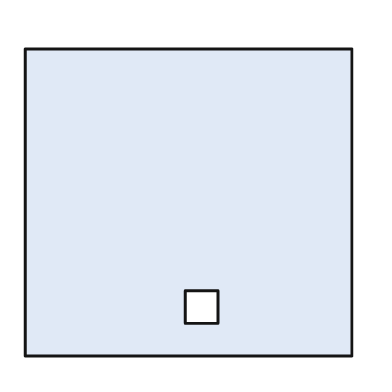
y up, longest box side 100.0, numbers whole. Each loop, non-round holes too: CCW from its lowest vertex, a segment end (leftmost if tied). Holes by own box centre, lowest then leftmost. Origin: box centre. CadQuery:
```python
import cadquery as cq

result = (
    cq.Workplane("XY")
    .moveTo(-50.0, -47.0)
    .lineTo(50.0, -47.0)
    .lineTo(50.0, 47.0)
    .lineTo(-50.0, 47.0)
    .close()
    .moveTo(-1.0, -37.0)
    .lineTo(9.0, -37.0)
    .lineTo(9.0, -27.0)
    .lineTo(-1.0, -27.0)
    .close()
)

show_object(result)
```